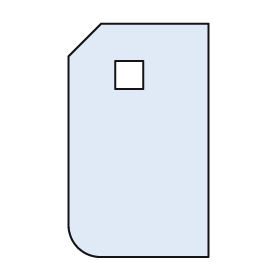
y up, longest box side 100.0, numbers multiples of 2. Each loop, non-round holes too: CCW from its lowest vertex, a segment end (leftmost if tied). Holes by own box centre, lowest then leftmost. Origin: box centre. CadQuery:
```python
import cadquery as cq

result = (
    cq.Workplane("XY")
    .moveTo(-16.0, -50.0)
    .lineTo(30.0, -50.0)
    .lineTo(30.0, 50.0)
    .lineTo(-16.0, 50.0)
    .lineTo(-30.0, 36.0)
    .lineTo(-30.0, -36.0)
    .threePointArc((-26.0, -46.0), (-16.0, -50.0))
    .close()
    .moveTo(-10.0, 22.0)
    .lineTo(2.0, 22.0)
    .lineTo(2.0, 34.0)
    .lineTo(-10.0, 34.0)
    .close()
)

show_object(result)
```